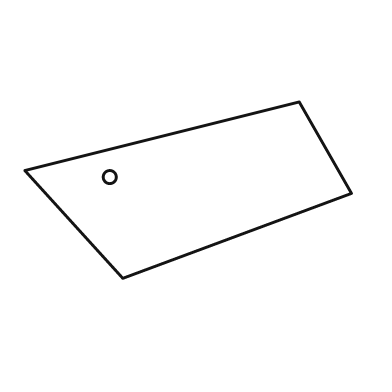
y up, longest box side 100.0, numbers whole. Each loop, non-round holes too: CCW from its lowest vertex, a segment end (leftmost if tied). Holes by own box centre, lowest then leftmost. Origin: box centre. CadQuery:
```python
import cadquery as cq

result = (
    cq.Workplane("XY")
    .moveTo(-20.0, -27.0)
    .lineTo(50.0, -1.0)
    .lineTo(34.0, 27.0)
    .lineTo(-50.0, 6.0)
    .close()
    .moveTo(-24.0, 4.0)
    .circle(2.0)
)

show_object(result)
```